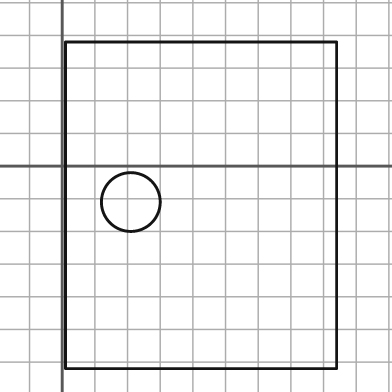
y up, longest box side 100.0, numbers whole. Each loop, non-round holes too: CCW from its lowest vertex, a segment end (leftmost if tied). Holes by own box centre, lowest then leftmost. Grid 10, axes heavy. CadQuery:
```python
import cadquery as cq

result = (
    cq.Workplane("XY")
    .moveTo(1.0, -62.0)
    .lineTo(84.0, -62.0)
    .lineTo(84.0, 38.0)
    .lineTo(1.0, 38.0)
    .close()
    .moveTo(21.0, -11.0)
    .circle(9.0)
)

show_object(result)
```